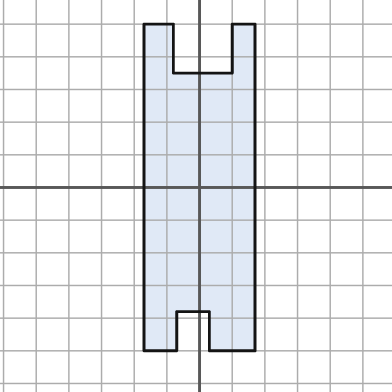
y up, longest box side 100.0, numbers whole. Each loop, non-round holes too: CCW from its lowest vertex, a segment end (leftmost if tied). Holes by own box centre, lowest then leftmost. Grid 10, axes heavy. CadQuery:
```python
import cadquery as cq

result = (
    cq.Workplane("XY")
    .moveTo(-17.0, -50.0)
    .lineTo(-7.0, -50.0)
    .lineTo(-7.0, -38.0)
    .lineTo(3.0, -38.0)
    .lineTo(3.0, -50.0)
    .lineTo(17.0, -50.0)
    .lineTo(17.0, 50.0)
    .lineTo(10.0, 50.0)
    .lineTo(10.0, 35.0)
    .lineTo(-8.0, 35.0)
    .lineTo(-8.0, 50.0)
    .lineTo(-17.0, 50.0)
    .close()
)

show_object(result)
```